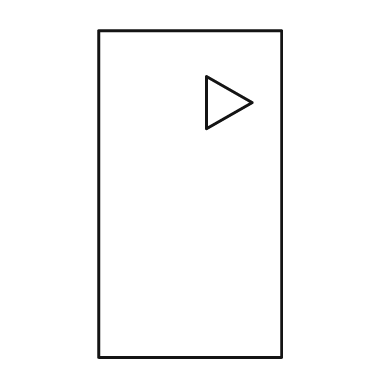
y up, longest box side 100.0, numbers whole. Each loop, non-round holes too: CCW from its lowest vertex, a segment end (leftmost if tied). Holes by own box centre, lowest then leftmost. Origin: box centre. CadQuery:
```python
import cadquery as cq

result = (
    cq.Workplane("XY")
    .moveTo(-28.0, -50.0)
    .lineTo(28.0, -50.0)
    .lineTo(28.0, 50.0)
    .lineTo(-28.0, 50.0)
    .close()
    .moveTo(5.0, 20.0)
    .lineTo(19.0, 28.0)
    .lineTo(5.0, 36.0)
    .close()
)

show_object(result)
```